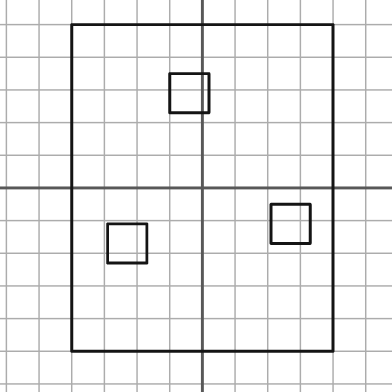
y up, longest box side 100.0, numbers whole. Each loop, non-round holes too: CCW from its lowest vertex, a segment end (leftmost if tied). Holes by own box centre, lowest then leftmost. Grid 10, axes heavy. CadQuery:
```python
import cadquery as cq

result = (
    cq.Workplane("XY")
    .moveTo(-40.0, -50.0)
    .lineTo(40.0, -50.0)
    .lineTo(40.0, 50.0)
    .lineTo(-40.0, 50.0)
    .close()
    .moveTo(-29.0, -23.0)
    .lineTo(-17.0, -23.0)
    .lineTo(-17.0, -11.0)
    .lineTo(-29.0, -11.0)
    .close()
    .moveTo(21.0, -17.0)
    .lineTo(33.0, -17.0)
    .lineTo(33.0, -5.0)
    .lineTo(21.0, -5.0)
    .close()
    .moveTo(-10.0, 23.0)
    .lineTo(2.0, 23.0)
    .lineTo(2.0, 35.0)
    .lineTo(-10.0, 35.0)
    .close()
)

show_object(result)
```